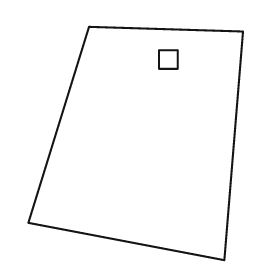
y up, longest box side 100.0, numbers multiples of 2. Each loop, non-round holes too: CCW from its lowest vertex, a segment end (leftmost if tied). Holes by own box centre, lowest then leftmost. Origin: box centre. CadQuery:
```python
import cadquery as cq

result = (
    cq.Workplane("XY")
    .moveTo(38.0, -50.0)
    .lineTo(46.0, 48.0)
    .lineTo(-20.0, 50.0)
    .lineTo(-46.0, -34.0)
    .close()
    .moveTo(10.0, 32.0)
    .lineTo(18.0, 32.0)
    .lineTo(18.0, 40.0)
    .lineTo(10.0, 40.0)
    .close()
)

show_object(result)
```